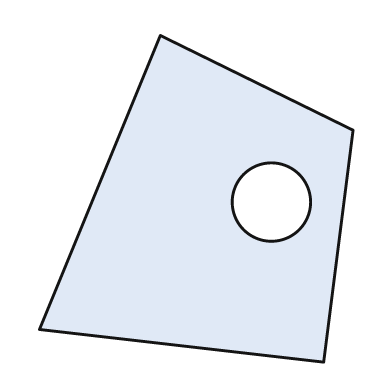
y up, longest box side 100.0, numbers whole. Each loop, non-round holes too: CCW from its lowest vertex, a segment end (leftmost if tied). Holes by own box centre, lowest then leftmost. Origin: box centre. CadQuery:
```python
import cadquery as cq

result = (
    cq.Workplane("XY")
    .moveTo(39.0, -50.0)
    .lineTo(48.0, 21.0)
    .lineTo(-11.0, 50.0)
    .lineTo(-48.0, -40.0)
    .close()
    .moveTo(23.0, -1.0)
    .circle(12.0)
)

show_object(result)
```